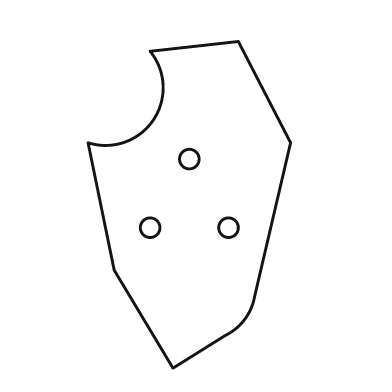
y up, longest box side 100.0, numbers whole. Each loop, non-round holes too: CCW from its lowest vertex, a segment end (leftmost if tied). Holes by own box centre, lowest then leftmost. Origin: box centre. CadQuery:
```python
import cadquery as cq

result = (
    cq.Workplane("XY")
    .moveTo(-5.0, -50.0)
    .lineTo(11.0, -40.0)
    .threePointArc((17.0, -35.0), (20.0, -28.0))
    .lineTo(31.0, 19.0)
    .lineTo(15.0, 50.0)
    .lineTo(-12.0, 47.0)
    .threePointArc((-11.0, 26.0), (-31.0, 19.0))
    .lineTo(-23.0, -20.0)
    .close()
    .moveTo(-12.0, -7.0)
    .circle(3.0)
    .moveTo(12.0, -7.0)
    .circle(3.0)
    .moveTo(0.0, 14.0)
    .circle(3.0)
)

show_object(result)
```